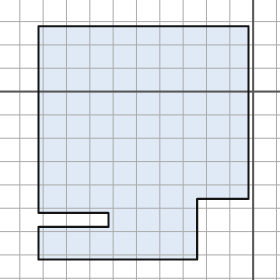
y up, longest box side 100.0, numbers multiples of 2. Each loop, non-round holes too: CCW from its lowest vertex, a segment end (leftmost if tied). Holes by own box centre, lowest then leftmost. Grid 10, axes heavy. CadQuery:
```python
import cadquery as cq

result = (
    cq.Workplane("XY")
    .moveTo(-92.0, -72.0)
    .lineTo(-24.0, -72.0)
    .lineTo(-24.0, -46.0)
    .lineTo(-2.0, -46.0)
    .lineTo(-2.0, 28.0)
    .lineTo(-92.0, 28.0)
    .lineTo(-92.0, -52.0)
    .lineTo(-62.0, -52.0)
    .lineTo(-62.0, -58.0)
    .lineTo(-92.0, -58.0)
    .close()
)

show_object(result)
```